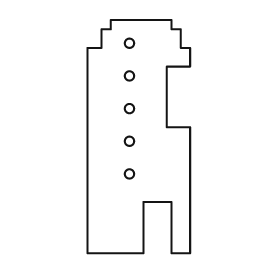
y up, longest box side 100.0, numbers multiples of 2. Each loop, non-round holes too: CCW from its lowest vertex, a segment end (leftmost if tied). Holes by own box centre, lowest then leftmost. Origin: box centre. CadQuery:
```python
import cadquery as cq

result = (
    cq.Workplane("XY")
    .moveTo(-22.0, -50.0)
    .lineTo(2.0, -50.0)
    .lineTo(2.0, -28.0)
    .lineTo(14.0, -28.0)
    .lineTo(14.0, -50.0)
    .lineTo(22.0, -50.0)
    .lineTo(22.0, 4.0)
    .lineTo(12.0, 4.0)
    .lineTo(12.0, 30.0)
    .lineTo(22.0, 30.0)
    .lineTo(22.0, 38.0)
    .lineTo(18.0, 38.0)
    .lineTo(18.0, 46.0)
    .lineTo(14.0, 46.0)
    .lineTo(14.0, 50.0)
    .lineTo(-12.0, 50.0)
    .lineTo(-12.0, 46.0)
    .lineTo(-16.0, 46.0)
    .lineTo(-16.0, 38.0)
    .lineTo(-22.0, 38.0)
    .close()
    .moveTo(-4.0, -16.0)
    .circle(2.0)
    .moveTo(-4.0, -2.0)
    .circle(2.0)
    .moveTo(-4.0, 12.0)
    .circle(2.0)
    .moveTo(-4.0, 26.0)
    .circle(2.0)
    .moveTo(-4.0, 40.0)
    .circle(2.0)
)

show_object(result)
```